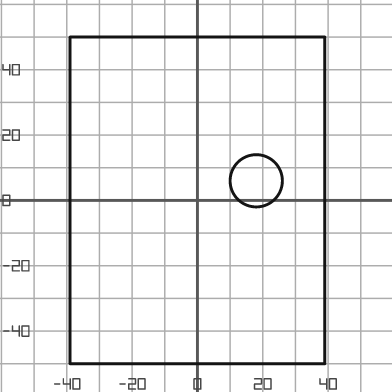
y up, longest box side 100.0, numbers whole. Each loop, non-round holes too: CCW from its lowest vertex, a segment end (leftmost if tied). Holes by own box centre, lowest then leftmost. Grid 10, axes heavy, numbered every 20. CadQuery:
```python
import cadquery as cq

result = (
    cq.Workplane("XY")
    .moveTo(-39.0, -50.0)
    .lineTo(39.0, -50.0)
    .lineTo(39.0, 50.0)
    .lineTo(-39.0, 50.0)
    .close()
    .moveTo(18.0, 6.0)
    .circle(8.0)
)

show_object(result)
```